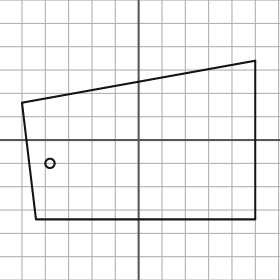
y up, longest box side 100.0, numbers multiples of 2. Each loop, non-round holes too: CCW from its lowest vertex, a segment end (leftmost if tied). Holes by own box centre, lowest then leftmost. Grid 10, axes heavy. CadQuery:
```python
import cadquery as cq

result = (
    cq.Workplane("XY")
    .moveTo(-44.0, -34.0)
    .lineTo(50.0, -34.0)
    .lineTo(50.0, 34.0)
    .lineTo(-50.0, 16.0)
    .close()
    .moveTo(-38.0, -10.0)
    .circle(2.0)
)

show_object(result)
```